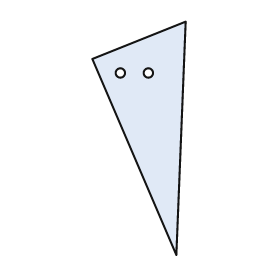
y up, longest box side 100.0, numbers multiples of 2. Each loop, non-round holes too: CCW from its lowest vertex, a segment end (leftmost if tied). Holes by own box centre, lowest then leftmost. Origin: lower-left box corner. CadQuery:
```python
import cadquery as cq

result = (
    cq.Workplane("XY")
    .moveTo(36.0, 0.0)
    .lineTo(40.0, 100.0)
    .lineTo(0.0, 84.0)
    .close()
    .moveTo(12.0, 78.0)
    .circle(2.0)
    .moveTo(24.0, 78.0)
    .circle(2.0)
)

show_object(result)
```